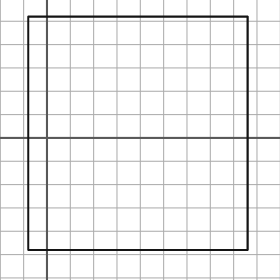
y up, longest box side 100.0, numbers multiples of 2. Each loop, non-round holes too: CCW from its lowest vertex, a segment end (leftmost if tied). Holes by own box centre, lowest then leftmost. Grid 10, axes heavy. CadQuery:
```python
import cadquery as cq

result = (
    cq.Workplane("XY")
    .moveTo(-8.0, -48.0)
    .lineTo(86.0, -48.0)
    .lineTo(86.0, 52.0)
    .lineTo(-8.0, 52.0)
    .close()
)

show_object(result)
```